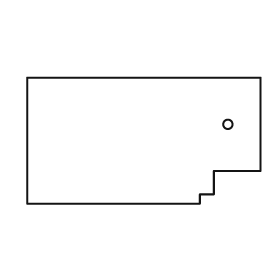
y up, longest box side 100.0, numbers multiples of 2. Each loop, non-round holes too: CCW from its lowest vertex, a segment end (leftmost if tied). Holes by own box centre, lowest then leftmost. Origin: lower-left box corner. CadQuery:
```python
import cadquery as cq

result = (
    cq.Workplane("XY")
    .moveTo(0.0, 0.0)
    .lineTo(74.0, 0.0)
    .lineTo(74.0, 4.0)
    .lineTo(80.0, 4.0)
    .lineTo(80.0, 14.0)
    .lineTo(100.0, 14.0)
    .lineTo(100.0, 54.0)
    .lineTo(0.0, 54.0)
    .close()
    .moveTo(86.0, 34.0)
    .circle(2.0)
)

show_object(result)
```